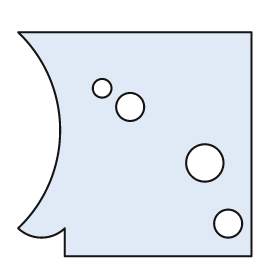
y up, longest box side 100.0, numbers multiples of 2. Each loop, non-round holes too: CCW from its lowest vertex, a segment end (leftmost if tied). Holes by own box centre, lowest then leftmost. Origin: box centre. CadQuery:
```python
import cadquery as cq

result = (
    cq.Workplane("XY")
    .moveTo(-30.0, -48.0)
    .lineTo(50.0, -48.0)
    .lineTo(50.0, 48.0)
    .lineTo(-50.0, 48.0)
    .threePointArc((-32.0, 6.0), (-50.0, -36.0))
    .threePointArc((-40.0, -40.0), (-30.0, -36.0))
    .close()
    .moveTo(40.0, -34.0)
    .circle(6.0)
    .moveTo(30.0, -8.0)
    .circle(8.0)
    .moveTo(-2.0, 16.0)
    .circle(6.0)
    .moveTo(-14.0, 24.0)
    .circle(4.0)
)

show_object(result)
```